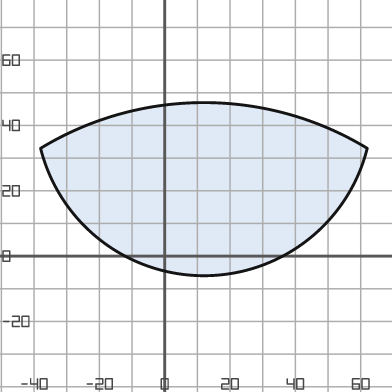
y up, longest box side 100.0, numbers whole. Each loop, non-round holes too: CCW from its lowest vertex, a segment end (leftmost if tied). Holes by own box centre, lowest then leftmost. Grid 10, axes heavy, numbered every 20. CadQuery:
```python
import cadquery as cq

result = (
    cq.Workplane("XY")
    .moveTo(-38.0, 33.0)
    .threePointArc((12.0, -6.0), (62.0, 33.0))
    .threePointArc((12.0, 47.0), (-38.0, 33.0))
    .close()
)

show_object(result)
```